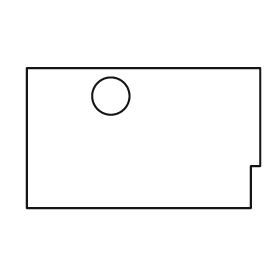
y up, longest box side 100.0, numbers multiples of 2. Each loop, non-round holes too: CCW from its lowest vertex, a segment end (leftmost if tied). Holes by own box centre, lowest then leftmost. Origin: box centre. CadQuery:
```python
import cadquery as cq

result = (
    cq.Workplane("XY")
    .moveTo(-50.0, -30.0)
    .lineTo(46.0, -30.0)
    .lineTo(46.0, -12.0)
    .lineTo(50.0, -12.0)
    .lineTo(50.0, 30.0)
    .lineTo(-50.0, 30.0)
    .close()
    .moveTo(-14.0, 18.0)
    .circle(8.0)
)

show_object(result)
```